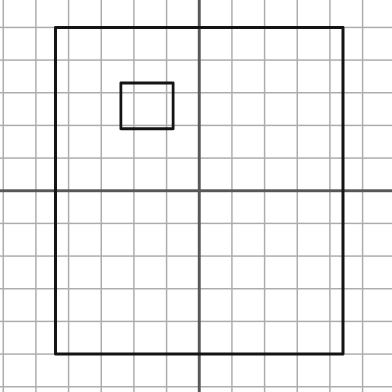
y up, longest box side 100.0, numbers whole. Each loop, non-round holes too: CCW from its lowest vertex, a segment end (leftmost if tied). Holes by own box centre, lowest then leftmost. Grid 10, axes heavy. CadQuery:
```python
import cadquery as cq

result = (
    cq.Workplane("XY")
    .moveTo(-44.0, -50.0)
    .lineTo(44.0, -50.0)
    .lineTo(44.0, 50.0)
    .lineTo(-44.0, 50.0)
    .close()
    .moveTo(-24.0, 19.0)
    .lineTo(-8.0, 19.0)
    .lineTo(-8.0, 33.0)
    .lineTo(-24.0, 33.0)
    .close()
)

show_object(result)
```